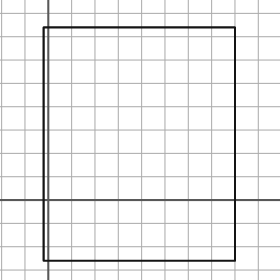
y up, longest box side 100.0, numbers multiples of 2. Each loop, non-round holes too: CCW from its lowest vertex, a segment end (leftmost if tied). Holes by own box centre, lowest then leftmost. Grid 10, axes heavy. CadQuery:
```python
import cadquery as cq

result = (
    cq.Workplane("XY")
    .moveTo(-2.0, -26.0)
    .lineTo(80.0, -26.0)
    .lineTo(80.0, 74.0)
    .lineTo(-2.0, 74.0)
    .close()
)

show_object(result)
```